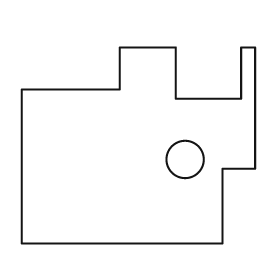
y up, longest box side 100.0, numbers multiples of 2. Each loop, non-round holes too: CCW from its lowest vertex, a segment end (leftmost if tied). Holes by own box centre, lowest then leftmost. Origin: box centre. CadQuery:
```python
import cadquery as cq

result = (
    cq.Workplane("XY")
    .moveTo(-50.0, -42.0)
    .lineTo(36.0, -42.0)
    .lineTo(36.0, -10.0)
    .lineTo(50.0, -10.0)
    .lineTo(50.0, 42.0)
    .lineTo(44.0, 42.0)
    .lineTo(44.0, 20.0)
    .lineTo(16.0, 20.0)
    .lineTo(16.0, 42.0)
    .lineTo(-8.0, 42.0)
    .lineTo(-8.0, 24.0)
    .lineTo(-50.0, 24.0)
    .close()
    .moveTo(20.0, -6.0)
    .circle(8.0)
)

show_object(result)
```